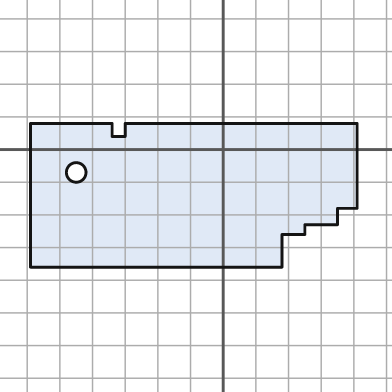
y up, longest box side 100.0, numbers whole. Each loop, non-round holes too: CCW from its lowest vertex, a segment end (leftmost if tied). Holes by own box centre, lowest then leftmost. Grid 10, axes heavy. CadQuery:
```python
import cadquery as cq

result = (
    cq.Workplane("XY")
    .moveTo(-59.0, -36.0)
    .lineTo(18.0, -36.0)
    .lineTo(18.0, -26.0)
    .lineTo(25.0, -26.0)
    .lineTo(25.0, -23.0)
    .lineTo(35.0, -23.0)
    .lineTo(35.0, -18.0)
    .lineTo(41.0, -18.0)
    .lineTo(41.0, 8.0)
    .lineTo(-30.0, 8.0)
    .lineTo(-30.0, 4.0)
    .lineTo(-34.0, 4.0)
    .lineTo(-34.0, 8.0)
    .lineTo(-59.0, 8.0)
    .close()
    .moveTo(-45.0, -7.0)
    .circle(3.0)
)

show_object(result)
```